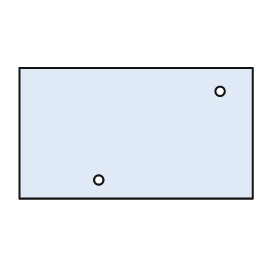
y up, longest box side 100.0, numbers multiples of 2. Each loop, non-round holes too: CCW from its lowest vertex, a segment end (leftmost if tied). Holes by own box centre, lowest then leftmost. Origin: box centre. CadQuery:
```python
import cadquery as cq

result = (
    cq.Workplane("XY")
    .moveTo(-50.0, -28.0)
    .lineTo(50.0, -28.0)
    .lineTo(50.0, 28.0)
    .lineTo(-50.0, 28.0)
    .close()
    .moveTo(-16.0, -20.0)
    .circle(2.0)
    .moveTo(36.0, 18.0)
    .circle(2.0)
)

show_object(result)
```